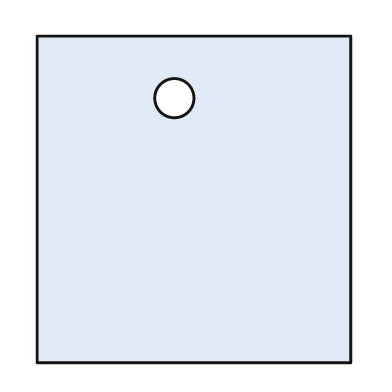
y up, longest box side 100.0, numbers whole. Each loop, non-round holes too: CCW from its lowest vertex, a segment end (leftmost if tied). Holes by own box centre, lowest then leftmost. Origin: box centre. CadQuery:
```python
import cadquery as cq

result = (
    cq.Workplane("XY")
    .moveTo(-48.0, -50.0)
    .lineTo(48.0, -50.0)
    .lineTo(48.0, 50.0)
    .lineTo(-48.0, 50.0)
    .close()
    .moveTo(-6.0, 31.0)
    .circle(6.0)
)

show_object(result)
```